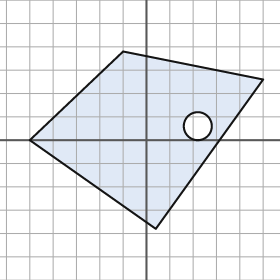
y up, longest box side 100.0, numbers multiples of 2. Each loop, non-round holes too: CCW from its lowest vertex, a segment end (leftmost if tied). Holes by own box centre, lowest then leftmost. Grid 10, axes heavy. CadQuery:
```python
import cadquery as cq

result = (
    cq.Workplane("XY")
    .moveTo(4.0, -38.0)
    .lineTo(50.0, 26.0)
    .lineTo(-10.0, 38.0)
    .lineTo(-50.0, 0.0)
    .close()
    .moveTo(22.0, 6.0)
    .circle(6.0)
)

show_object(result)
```